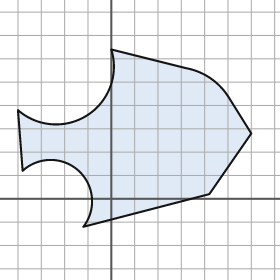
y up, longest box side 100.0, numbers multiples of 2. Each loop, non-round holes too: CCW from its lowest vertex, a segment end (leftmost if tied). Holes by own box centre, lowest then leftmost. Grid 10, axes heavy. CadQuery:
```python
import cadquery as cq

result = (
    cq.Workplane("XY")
    .moveTo(-12.0, -12.0)
    .lineTo(42.0, 2.0)
    .lineTo(60.0, 28.0)
    .lineTo(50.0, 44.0)
    .threePointArc((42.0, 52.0), (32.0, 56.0))
    .lineTo(0.0, 64.0)
    .threePointArc((-10.0, 36.0), (-40.0, 38.0))
    .lineTo(-38.0, 12.0)
    .threePointArc((-14.0, 12.0), (-12.0, -12.0))
    .close()
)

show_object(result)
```